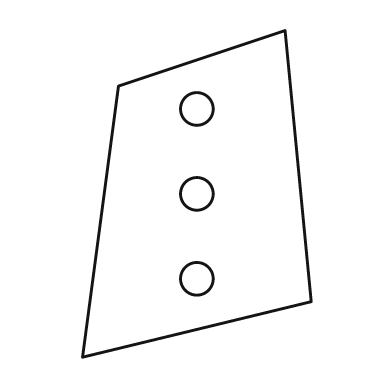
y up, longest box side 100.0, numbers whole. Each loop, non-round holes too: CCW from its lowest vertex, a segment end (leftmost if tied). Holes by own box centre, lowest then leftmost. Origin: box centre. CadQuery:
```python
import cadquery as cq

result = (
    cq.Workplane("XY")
    .moveTo(-35.0, -50.0)
    .lineTo(35.0, -33.0)
    .lineTo(27.0, 50.0)
    .lineTo(-24.0, 33.0)
    .close()
    .moveTo(0.0, -26.0)
    .circle(5.0)
    .moveTo(0.0, 0.0)
    .circle(5.0)
    .moveTo(0.0, 26.0)
    .circle(5.0)
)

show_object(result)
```